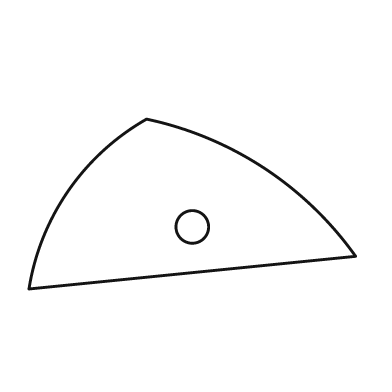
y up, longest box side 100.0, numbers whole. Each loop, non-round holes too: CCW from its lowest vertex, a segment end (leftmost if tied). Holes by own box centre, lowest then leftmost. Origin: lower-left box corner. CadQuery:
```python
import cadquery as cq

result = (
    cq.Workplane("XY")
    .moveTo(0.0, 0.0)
    .lineTo(100.0, 10.0)
    .threePointArc((72.0, 37.0), (36.0, 52.0))
    .threePointArc((12.0, 30.0), (0.0, 0.0))
    .close()
    .moveTo(50.0, 19.0)
    .circle(5.0)
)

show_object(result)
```